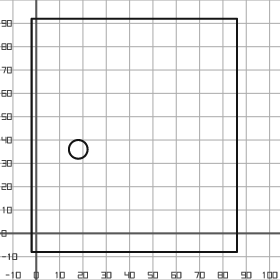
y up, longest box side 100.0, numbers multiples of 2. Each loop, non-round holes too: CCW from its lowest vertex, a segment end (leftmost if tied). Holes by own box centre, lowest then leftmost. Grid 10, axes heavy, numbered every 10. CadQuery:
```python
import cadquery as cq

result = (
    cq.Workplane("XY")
    .moveTo(-2.0, -8.0)
    .lineTo(86.0, -8.0)
    .lineTo(86.0, 92.0)
    .lineTo(-2.0, 92.0)
    .close()
    .moveTo(18.0, 36.0)
    .circle(4.0)
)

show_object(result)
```